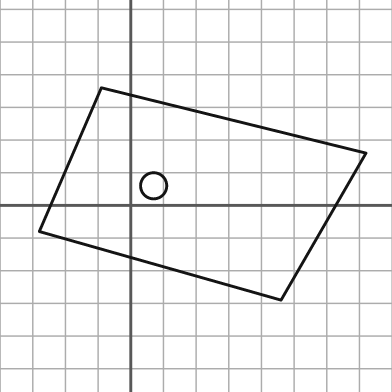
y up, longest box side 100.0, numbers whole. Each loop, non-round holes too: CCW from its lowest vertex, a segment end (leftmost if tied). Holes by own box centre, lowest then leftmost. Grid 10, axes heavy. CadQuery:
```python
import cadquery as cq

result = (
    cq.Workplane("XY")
    .moveTo(46.0, -29.0)
    .lineTo(72.0, 16.0)
    .lineTo(-9.0, 36.0)
    .lineTo(-28.0, -8.0)
    .close()
    .moveTo(7.0, 6.0)
    .circle(4.0)
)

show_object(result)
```